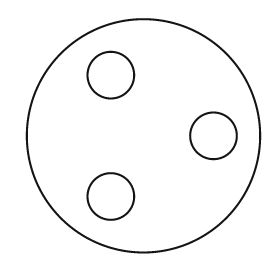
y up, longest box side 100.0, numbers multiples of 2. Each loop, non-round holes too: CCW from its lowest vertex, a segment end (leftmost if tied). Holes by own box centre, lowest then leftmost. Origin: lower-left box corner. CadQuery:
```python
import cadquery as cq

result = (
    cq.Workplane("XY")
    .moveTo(50.0, 50.0)
    .circle(50.0)
    .moveTo(36.0, 24.0)
    .circle(10.0)
    .moveTo(80.0, 50.0)
    .circle(10.0)
    .moveTo(36.0, 76.0)
    .circle(10.0)
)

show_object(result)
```